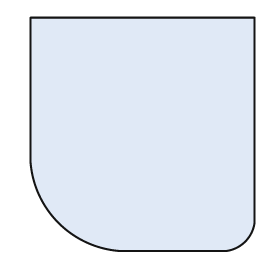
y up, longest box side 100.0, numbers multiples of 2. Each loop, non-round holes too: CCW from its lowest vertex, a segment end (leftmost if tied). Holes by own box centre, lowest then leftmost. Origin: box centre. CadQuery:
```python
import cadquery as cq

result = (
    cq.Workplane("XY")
    .moveTo(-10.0, -50.0)
    .lineTo(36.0, -50.0)
    .threePointArc((44.0, -46.0), (48.0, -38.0))
    .lineTo(48.0, 50.0)
    .lineTo(-48.0, 50.0)
    .lineTo(-48.0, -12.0)
    .threePointArc((-36.0, -38.0), (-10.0, -50.0))
    .close()
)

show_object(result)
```